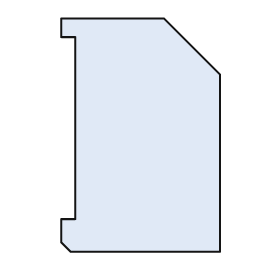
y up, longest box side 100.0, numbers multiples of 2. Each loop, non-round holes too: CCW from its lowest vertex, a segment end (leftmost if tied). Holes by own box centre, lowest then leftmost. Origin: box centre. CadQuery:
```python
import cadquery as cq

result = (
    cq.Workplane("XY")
    .moveTo(-30.0, -50.0)
    .lineTo(34.0, -50.0)
    .lineTo(34.0, 26.0)
    .lineTo(10.0, 50.0)
    .lineTo(-34.0, 50.0)
    .lineTo(-34.0, 42.0)
    .lineTo(-28.0, 42.0)
    .lineTo(-28.0, -36.0)
    .lineTo(-34.0, -36.0)
    .lineTo(-34.0, -46.0)
    .close()
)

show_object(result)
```